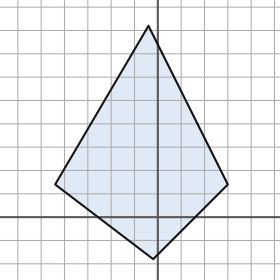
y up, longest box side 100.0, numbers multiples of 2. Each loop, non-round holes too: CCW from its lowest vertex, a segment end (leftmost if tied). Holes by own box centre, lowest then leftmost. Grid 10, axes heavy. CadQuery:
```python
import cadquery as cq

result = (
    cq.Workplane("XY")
    .moveTo(-2.0, -18.0)
    .lineTo(30.0, 14.0)
    .lineTo(-4.0, 82.0)
    .lineTo(-44.0, 14.0)
    .close()
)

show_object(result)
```